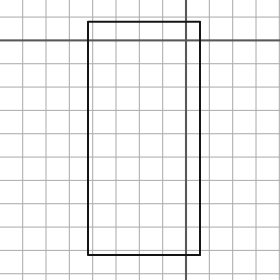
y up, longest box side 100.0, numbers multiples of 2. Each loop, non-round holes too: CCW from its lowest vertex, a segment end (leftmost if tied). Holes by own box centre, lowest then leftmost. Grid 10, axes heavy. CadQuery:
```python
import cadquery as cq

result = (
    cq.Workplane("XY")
    .moveTo(-42.0, -92.0)
    .lineTo(6.0, -92.0)
    .lineTo(6.0, 8.0)
    .lineTo(-42.0, 8.0)
    .close()
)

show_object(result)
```